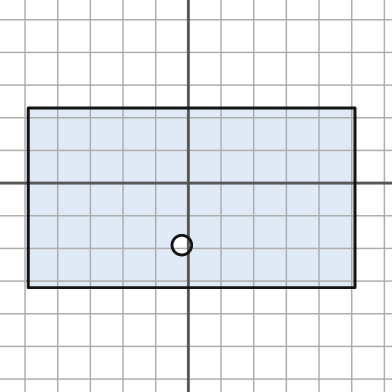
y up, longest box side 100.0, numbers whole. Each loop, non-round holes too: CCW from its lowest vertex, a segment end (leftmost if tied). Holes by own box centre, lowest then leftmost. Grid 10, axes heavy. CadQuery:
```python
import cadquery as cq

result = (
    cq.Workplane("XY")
    .moveTo(-49.0, -32.0)
    .lineTo(51.0, -32.0)
    .lineTo(51.0, 23.0)
    .lineTo(-49.0, 23.0)
    .close()
    .moveTo(-2.0, -19.0)
    .circle(3.0)
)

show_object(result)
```